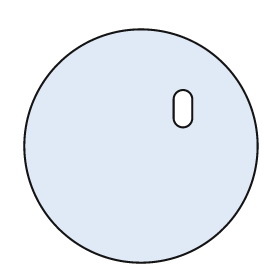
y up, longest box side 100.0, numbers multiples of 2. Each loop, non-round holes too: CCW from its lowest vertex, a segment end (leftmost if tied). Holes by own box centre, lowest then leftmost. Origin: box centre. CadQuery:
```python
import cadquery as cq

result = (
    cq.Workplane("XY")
    .moveTo(0.0, 0.0)
    .circle(50.0)
    .moveTo(14.0, 12.0)
    .threePointArc((18.0, 8.0), (22.0, 12.0))
    .lineTo(22.0, 20.0)
    .threePointArc((18.0, 24.0), (14.0, 20.0))
    .close()
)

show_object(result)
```